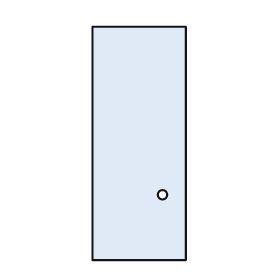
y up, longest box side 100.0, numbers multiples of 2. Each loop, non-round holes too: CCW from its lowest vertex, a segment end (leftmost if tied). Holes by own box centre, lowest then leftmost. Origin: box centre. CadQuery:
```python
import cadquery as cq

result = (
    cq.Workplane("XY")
    .moveTo(-20.0, -50.0)
    .lineTo(20.0, -50.0)
    .lineTo(20.0, 50.0)
    .lineTo(-20.0, 50.0)
    .close()
    .moveTo(10.0, -22.0)
    .circle(2.0)
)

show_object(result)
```